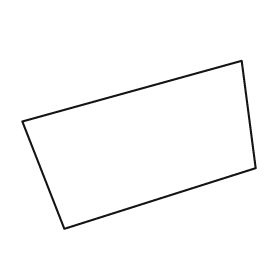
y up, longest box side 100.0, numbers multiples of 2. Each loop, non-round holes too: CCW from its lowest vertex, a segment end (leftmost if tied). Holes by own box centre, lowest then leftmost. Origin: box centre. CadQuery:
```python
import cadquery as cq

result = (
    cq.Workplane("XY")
    .moveTo(-32.0, -36.0)
    .lineTo(50.0, -10.0)
    .lineTo(44.0, 36.0)
    .lineTo(-50.0, 10.0)
    .close()
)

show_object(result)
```